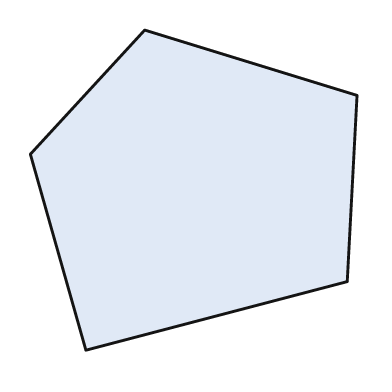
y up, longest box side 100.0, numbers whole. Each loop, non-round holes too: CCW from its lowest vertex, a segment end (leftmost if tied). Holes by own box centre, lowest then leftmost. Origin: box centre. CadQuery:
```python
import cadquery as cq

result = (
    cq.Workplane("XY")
    .moveTo(-33.0, -49.0)
    .lineTo(47.0, -28.0)
    .lineTo(50.0, 29.0)
    .lineTo(-15.0, 49.0)
    .lineTo(-50.0, 11.0)
    .close()
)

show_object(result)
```